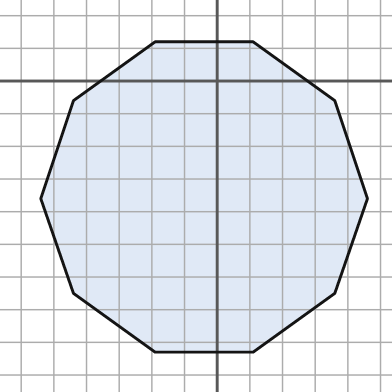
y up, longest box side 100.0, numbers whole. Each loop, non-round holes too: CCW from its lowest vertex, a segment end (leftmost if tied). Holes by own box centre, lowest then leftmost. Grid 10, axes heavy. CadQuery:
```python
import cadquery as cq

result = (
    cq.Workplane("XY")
    .moveTo(-19.0, -83.0)
    .lineTo(11.0, -83.0)
    .lineTo(36.0, -65.0)
    .lineTo(46.0, -36.0)
    .lineTo(36.0, -6.0)
    .lineTo(11.0, 12.0)
    .lineTo(-19.0, 12.0)
    .lineTo(-44.0, -6.0)
    .lineTo(-54.0, -36.0)
    .lineTo(-44.0, -65.0)
    .close()
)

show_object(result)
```